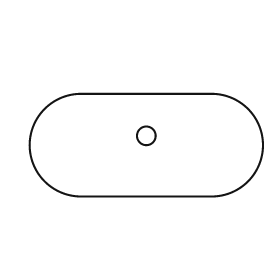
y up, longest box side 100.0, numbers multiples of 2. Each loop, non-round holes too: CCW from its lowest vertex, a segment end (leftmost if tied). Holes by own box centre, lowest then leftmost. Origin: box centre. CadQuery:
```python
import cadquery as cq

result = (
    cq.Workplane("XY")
    .moveTo(-28.0, -22.0)
    .lineTo(28.0, -22.0)
    .threePointArc((50.0, 0.0), (28.0, 22.0))
    .lineTo(-28.0, 22.0)
    .threePointArc((-50.0, 0.0), (-28.0, -22.0))
    .close()
    .moveTo(0.0, 4.0)
    .circle(4.0)
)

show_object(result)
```